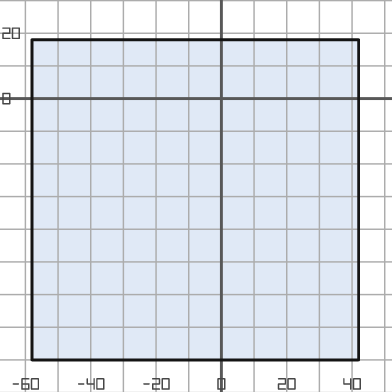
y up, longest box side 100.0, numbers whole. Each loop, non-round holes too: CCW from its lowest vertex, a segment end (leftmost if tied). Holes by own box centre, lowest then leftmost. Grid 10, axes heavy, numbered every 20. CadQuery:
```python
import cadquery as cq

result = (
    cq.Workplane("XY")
    .moveTo(-58.0, -80.0)
    .lineTo(42.0, -80.0)
    .lineTo(42.0, 18.0)
    .lineTo(-58.0, 18.0)
    .close()
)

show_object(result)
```